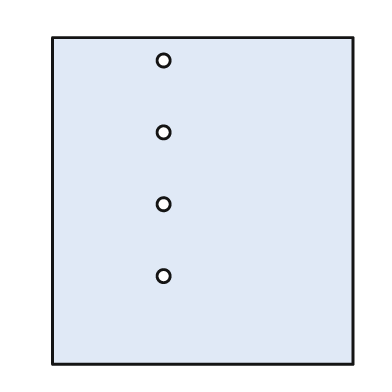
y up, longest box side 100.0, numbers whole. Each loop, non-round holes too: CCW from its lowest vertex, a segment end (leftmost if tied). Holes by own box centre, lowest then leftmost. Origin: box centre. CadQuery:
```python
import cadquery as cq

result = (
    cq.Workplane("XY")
    .moveTo(-46.0, -50.0)
    .lineTo(46.0, -50.0)
    .lineTo(46.0, 50.0)
    .lineTo(-46.0, 50.0)
    .close()
    .moveTo(-12.0, -23.0)
    .circle(2.0)
    .moveTo(-12.0, -1.0)
    .circle(2.0)
    .moveTo(-12.0, 21.0)
    .circle(2.0)
    .moveTo(-12.0, 43.0)
    .circle(2.0)
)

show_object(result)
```